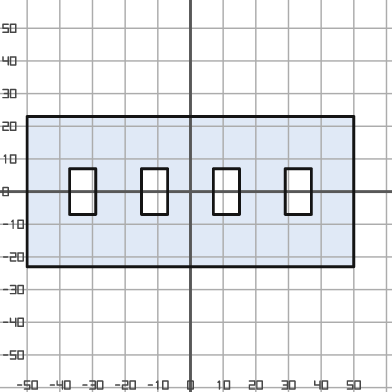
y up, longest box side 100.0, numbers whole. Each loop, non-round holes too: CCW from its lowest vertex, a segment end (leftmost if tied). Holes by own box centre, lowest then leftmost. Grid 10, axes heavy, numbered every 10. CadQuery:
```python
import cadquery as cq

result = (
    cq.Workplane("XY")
    .moveTo(-50.0, -23.0)
    .lineTo(50.0, -23.0)
    .lineTo(50.0, 23.0)
    .lineTo(-50.0, 23.0)
    .close()
    .moveTo(-37.0, -7.0)
    .lineTo(-29.0, -7.0)
    .lineTo(-29.0, 7.0)
    .lineTo(-37.0, 7.0)
    .close()
    .moveTo(-15.0, -7.0)
    .lineTo(-7.0, -7.0)
    .lineTo(-7.0, 7.0)
    .lineTo(-15.0, 7.0)
    .close()
    .moveTo(7.0, -7.0)
    .lineTo(15.0, -7.0)
    .lineTo(15.0, 7.0)
    .lineTo(7.0, 7.0)
    .close()
    .moveTo(29.0, -7.0)
    .lineTo(37.0, -7.0)
    .lineTo(37.0, 7.0)
    .lineTo(29.0, 7.0)
    .close()
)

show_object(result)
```